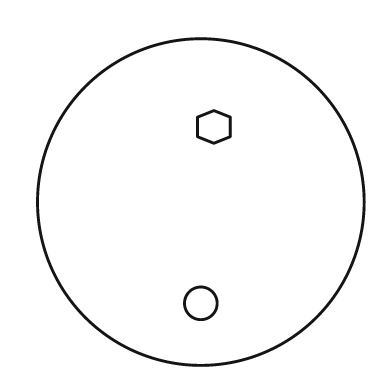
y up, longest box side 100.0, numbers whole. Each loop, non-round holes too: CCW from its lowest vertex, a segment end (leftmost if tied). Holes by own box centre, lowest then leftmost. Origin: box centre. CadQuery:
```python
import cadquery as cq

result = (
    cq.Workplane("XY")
    .moveTo(0.0, 0.0)
    .circle(50.0)
    .moveTo(0.0, -31.0)
    .circle(5.0)
    .moveTo(4.0, 18.0)
    .lineTo(9.0, 20.0)
    .lineTo(9.0, 26.0)
    .lineTo(4.0, 28.0)
    .lineTo(-1.0, 26.0)
    .lineTo(-1.0, 20.0)
    .close()
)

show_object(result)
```